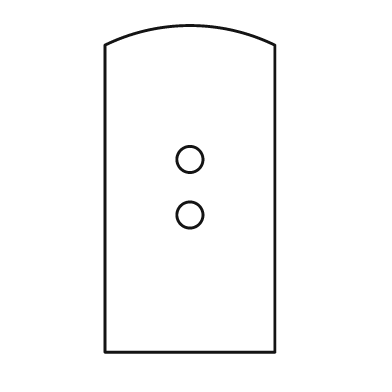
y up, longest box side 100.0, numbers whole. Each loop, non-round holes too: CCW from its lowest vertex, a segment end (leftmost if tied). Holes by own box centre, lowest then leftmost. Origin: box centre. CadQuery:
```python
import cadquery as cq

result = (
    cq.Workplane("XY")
    .moveTo(-26.0, -50.0)
    .lineTo(26.0, -50.0)
    .lineTo(26.0, 44.0)
    .threePointArc((0.0, 50.0), (-26.0, 44.0))
    .close()
    .moveTo(0.0, -8.0)
    .circle(4.0)
    .moveTo(0.0, 9.0)
    .circle(4.0)
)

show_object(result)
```